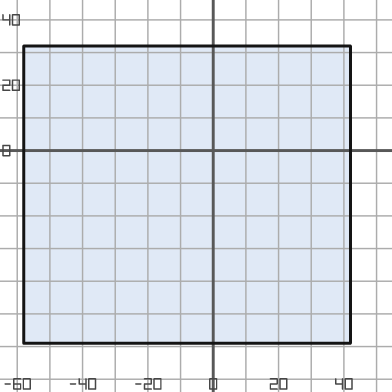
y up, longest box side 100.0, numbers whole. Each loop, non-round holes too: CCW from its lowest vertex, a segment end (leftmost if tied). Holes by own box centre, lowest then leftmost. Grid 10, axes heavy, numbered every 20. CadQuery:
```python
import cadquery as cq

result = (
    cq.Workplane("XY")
    .moveTo(-58.0, -59.0)
    .lineTo(42.0, -59.0)
    .lineTo(42.0, 32.0)
    .lineTo(-58.0, 32.0)
    .close()
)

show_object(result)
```